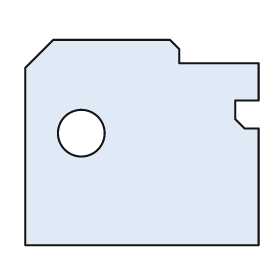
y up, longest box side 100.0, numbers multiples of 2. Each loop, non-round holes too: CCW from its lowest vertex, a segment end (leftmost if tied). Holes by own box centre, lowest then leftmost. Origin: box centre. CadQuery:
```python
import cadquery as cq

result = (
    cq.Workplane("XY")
    .moveTo(-50.0, -44.0)
    .lineTo(50.0, -44.0)
    .lineTo(50.0, 6.0)
    .lineTo(44.0, 6.0)
    .lineTo(40.0, 10.0)
    .lineTo(40.0, 18.0)
    .lineTo(50.0, 18.0)
    .lineTo(50.0, 34.0)
    .lineTo(16.0, 34.0)
    .lineTo(16.0, 40.0)
    .lineTo(12.0, 44.0)
    .lineTo(-38.0, 44.0)
    .lineTo(-50.0, 32.0)
    .close()
    .moveTo(-26.0, 4.0)
    .circle(10.0)
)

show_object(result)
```